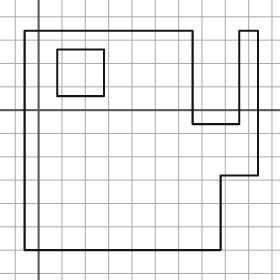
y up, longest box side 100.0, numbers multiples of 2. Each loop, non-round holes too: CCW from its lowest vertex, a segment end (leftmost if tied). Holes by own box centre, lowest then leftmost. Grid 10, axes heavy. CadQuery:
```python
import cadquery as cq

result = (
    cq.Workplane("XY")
    .moveTo(-6.0, -60.0)
    .lineTo(78.0, -60.0)
    .lineTo(78.0, -28.0)
    .lineTo(94.0, -28.0)
    .lineTo(94.0, 34.0)
    .lineTo(86.0, 34.0)
    .lineTo(86.0, -6.0)
    .lineTo(66.0, -6.0)
    .lineTo(66.0, 34.0)
    .lineTo(-6.0, 34.0)
    .close()
    .moveTo(8.0, 6.0)
    .lineTo(28.0, 6.0)
    .lineTo(28.0, 26.0)
    .lineTo(8.0, 26.0)
    .close()
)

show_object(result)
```